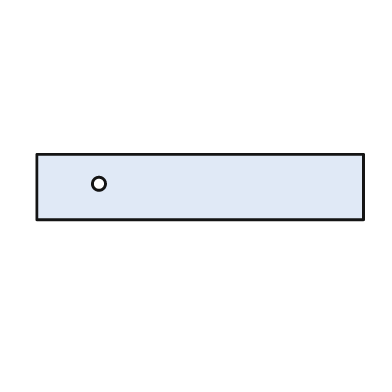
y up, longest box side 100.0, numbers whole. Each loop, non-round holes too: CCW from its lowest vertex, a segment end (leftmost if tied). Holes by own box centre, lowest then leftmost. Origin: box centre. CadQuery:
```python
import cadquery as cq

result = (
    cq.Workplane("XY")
    .moveTo(-50.0, -10.0)
    .lineTo(50.0, -10.0)
    .lineTo(50.0, 10.0)
    .lineTo(-50.0, 10.0)
    .close()
    .moveTo(-31.0, 1.0)
    .circle(2.0)
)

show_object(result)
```